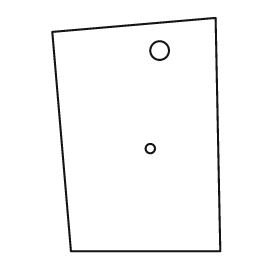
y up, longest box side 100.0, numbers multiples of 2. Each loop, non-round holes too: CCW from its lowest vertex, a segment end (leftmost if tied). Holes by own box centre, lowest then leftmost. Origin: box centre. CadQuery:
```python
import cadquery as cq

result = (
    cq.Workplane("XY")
    .moveTo(-28.0, -50.0)
    .lineTo(36.0, -50.0)
    .lineTo(34.0, 50.0)
    .lineTo(-36.0, 44.0)
    .close()
    .moveTo(6.0, -6.0)
    .circle(2.0)
    .moveTo(10.0, 36.0)
    .circle(4.0)
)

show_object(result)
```